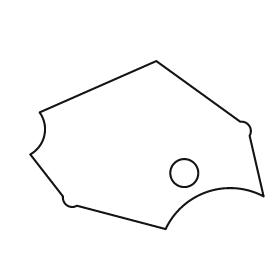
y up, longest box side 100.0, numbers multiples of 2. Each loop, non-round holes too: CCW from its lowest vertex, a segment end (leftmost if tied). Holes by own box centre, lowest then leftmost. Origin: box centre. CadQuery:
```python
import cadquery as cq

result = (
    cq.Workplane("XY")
    .moveTo(8.0, -36.0)
    .threePointArc((26.0, -20.0), (50.0, -22.0))
    .lineTo(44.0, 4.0)
    .threePointArc((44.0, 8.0), (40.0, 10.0))
    .lineTo(4.0, 36.0)
    .lineTo(-46.0, 14.0)
    .threePointArc((-44.0, 4.0), (-50.0, -4.0))
    .lineTo(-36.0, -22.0)
    .threePointArc((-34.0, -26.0), (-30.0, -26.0))
    .close()
    .moveTo(16.0, -12.0)
    .circle(6.0)
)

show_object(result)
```